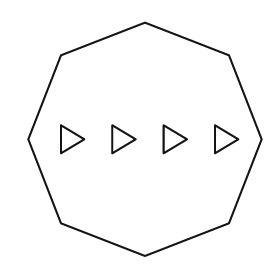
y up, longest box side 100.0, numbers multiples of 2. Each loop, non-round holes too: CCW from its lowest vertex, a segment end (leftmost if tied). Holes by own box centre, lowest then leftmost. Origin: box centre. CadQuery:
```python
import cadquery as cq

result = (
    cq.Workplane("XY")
    .moveTo(0.0, -50.0)
    .lineTo(36.0, -36.0)
    .lineTo(50.0, 0.0)
    .lineTo(36.0, 36.0)
    .lineTo(0.0, 50.0)
    .lineTo(-36.0, 36.0)
    .lineTo(-50.0, 0.0)
    .lineTo(-36.0, -36.0)
    .close()
    .moveTo(-36.0, -6.0)
    .lineTo(-26.0, 0.0)
    .lineTo(-36.0, 6.0)
    .close()
    .moveTo(-14.0, -6.0)
    .lineTo(-4.0, 0.0)
    .lineTo(-14.0, 6.0)
    .close()
    .moveTo(8.0, -6.0)
    .lineTo(18.0, 0.0)
    .lineTo(8.0, 6.0)
    .close()
    .moveTo(30.0, -6.0)
    .lineTo(40.0, 0.0)
    .lineTo(30.0, 6.0)
    .close()
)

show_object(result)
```